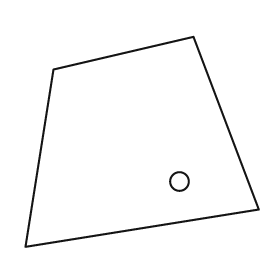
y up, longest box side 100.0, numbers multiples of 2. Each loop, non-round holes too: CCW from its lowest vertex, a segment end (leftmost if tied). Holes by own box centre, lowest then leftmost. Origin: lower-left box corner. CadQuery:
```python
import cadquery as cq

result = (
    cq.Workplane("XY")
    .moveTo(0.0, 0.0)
    .lineTo(100.0, 16.0)
    .lineTo(72.0, 90.0)
    .lineTo(12.0, 76.0)
    .close()
    .moveTo(66.0, 28.0)
    .circle(4.0)
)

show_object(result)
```